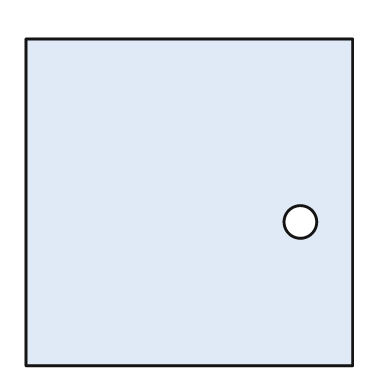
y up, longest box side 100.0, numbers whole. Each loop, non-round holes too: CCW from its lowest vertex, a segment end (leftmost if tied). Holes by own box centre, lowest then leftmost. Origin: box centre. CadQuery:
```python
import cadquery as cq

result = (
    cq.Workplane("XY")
    .moveTo(-50.0, -50.0)
    .lineTo(50.0, -50.0)
    .lineTo(50.0, 50.0)
    .lineTo(-50.0, 50.0)
    .close()
    .moveTo(34.0, -6.0)
    .circle(5.0)
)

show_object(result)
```